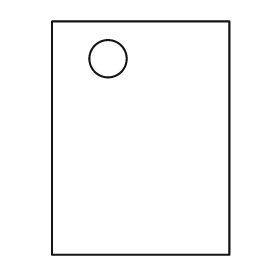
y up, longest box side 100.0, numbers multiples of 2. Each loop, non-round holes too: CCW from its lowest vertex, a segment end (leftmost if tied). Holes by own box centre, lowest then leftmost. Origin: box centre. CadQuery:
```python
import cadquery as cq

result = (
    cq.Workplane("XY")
    .moveTo(-38.0, -50.0)
    .lineTo(38.0, -50.0)
    .lineTo(38.0, 50.0)
    .lineTo(-38.0, 50.0)
    .close()
    .moveTo(-14.0, 34.0)
    .circle(8.0)
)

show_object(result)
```